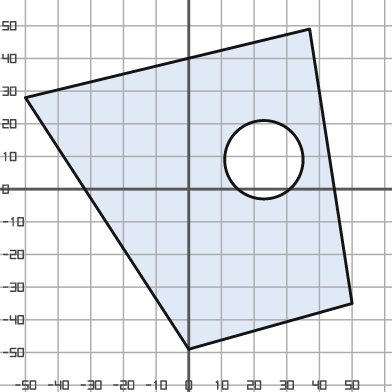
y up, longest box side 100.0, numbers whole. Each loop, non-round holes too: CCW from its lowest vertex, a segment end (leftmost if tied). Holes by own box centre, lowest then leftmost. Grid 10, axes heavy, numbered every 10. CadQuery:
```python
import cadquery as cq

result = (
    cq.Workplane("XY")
    .moveTo(0.0, -49.0)
    .lineTo(50.0, -35.0)
    .lineTo(37.0, 49.0)
    .lineTo(-50.0, 28.0)
    .close()
    .moveTo(23.0, 9.0)
    .circle(12.0)
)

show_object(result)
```